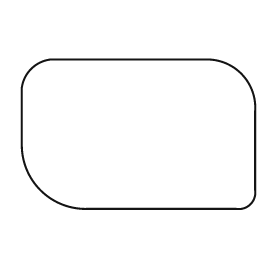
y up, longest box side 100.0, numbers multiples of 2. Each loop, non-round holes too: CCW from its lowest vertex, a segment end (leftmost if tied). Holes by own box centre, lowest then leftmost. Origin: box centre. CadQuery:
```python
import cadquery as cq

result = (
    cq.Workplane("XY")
    .moveTo(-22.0, -32.0)
    .lineTo(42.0, -32.0)
    .threePointArc((48.0, -30.0), (50.0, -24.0))
    .lineTo(50.0, 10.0)
    .threePointArc((44.0, 26.0), (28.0, 32.0))
    .lineTo(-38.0, 32.0)
    .threePointArc((-46.0, 28.0), (-50.0, 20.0))
    .lineTo(-50.0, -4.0)
    .threePointArc((-42.0, -24.0), (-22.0, -32.0))
    .close()
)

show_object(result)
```